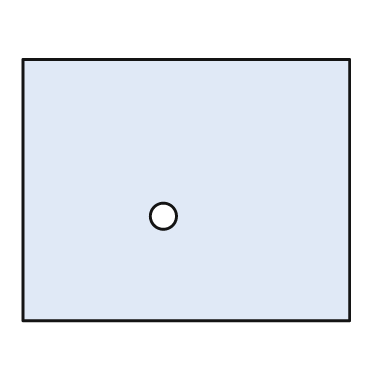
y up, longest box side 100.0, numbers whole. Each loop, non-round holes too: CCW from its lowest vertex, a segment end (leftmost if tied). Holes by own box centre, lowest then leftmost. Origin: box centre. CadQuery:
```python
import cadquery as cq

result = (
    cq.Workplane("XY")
    .moveTo(-50.0, -40.0)
    .lineTo(50.0, -40.0)
    .lineTo(50.0, 40.0)
    .lineTo(-50.0, 40.0)
    .close()
    .moveTo(-7.0, -8.0)
    .circle(4.0)
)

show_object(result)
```